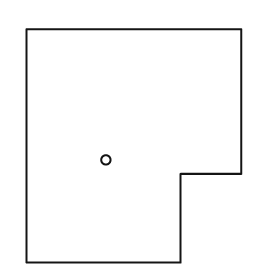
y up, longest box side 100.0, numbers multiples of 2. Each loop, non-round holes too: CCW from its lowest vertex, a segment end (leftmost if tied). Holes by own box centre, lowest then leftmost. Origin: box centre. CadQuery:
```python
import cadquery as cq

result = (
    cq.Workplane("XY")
    .moveTo(-46.0, -50.0)
    .lineTo(20.0, -50.0)
    .lineTo(20.0, -12.0)
    .lineTo(46.0, -12.0)
    .lineTo(46.0, 50.0)
    .lineTo(-46.0, 50.0)
    .close()
    .moveTo(-12.0, -6.0)
    .circle(2.0)
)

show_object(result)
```